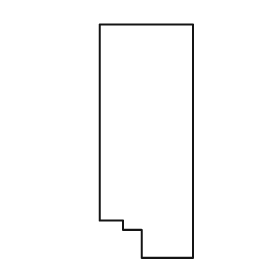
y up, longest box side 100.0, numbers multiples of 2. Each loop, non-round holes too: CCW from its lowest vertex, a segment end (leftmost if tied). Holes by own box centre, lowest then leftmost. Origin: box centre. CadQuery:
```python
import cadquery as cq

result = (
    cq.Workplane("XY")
    .moveTo(-2.0, -50.0)
    .lineTo(20.0, -50.0)
    .lineTo(20.0, 50.0)
    .lineTo(-20.0, 50.0)
    .lineTo(-20.0, -34.0)
    .lineTo(-10.0, -34.0)
    .lineTo(-10.0, -38.0)
    .lineTo(-2.0, -38.0)
    .close()
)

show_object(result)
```